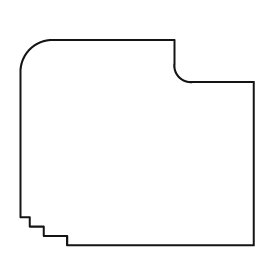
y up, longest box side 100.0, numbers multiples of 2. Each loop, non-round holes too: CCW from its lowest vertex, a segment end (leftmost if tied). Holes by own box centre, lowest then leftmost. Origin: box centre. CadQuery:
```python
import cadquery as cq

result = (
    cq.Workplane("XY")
    .moveTo(-30.0, -44.0)
    .lineTo(50.0, -44.0)
    .lineTo(50.0, 26.0)
    .lineTo(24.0, 26.0)
    .threePointArc((18.0, 28.0), (16.0, 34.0))
    .lineTo(16.0, 44.0)
    .lineTo(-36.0, 44.0)
    .threePointArc((-46.0, 40.0), (-50.0, 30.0))
    .lineTo(-50.0, -32.0)
    .lineTo(-46.0, -32.0)
    .lineTo(-46.0, -36.0)
    .lineTo(-40.0, -36.0)
    .lineTo(-40.0, -40.0)
    .lineTo(-30.0, -40.0)
    .close()
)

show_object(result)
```